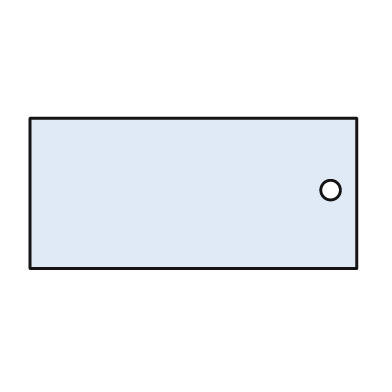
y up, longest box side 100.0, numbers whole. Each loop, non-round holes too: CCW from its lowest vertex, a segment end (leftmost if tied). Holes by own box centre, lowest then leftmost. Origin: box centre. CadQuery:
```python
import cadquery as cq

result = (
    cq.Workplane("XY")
    .moveTo(-50.0, -23.0)
    .lineTo(50.0, -23.0)
    .lineTo(50.0, 23.0)
    .lineTo(-50.0, 23.0)
    .close()
    .moveTo(42.0, 1.0)
    .circle(3.0)
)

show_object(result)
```